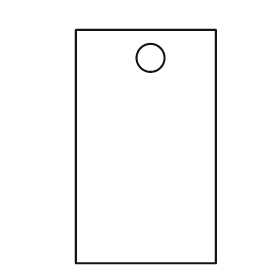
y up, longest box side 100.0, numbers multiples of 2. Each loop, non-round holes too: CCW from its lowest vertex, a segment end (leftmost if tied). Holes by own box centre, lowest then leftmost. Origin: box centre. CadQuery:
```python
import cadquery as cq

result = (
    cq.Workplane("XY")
    .moveTo(-30.0, -50.0)
    .lineTo(30.0, -50.0)
    .lineTo(30.0, 50.0)
    .lineTo(-30.0, 50.0)
    .close()
    .moveTo(2.0, 38.0)
    .circle(6.0)
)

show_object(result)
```